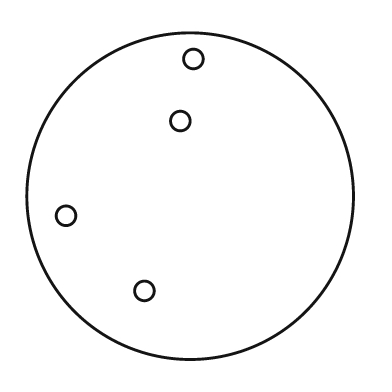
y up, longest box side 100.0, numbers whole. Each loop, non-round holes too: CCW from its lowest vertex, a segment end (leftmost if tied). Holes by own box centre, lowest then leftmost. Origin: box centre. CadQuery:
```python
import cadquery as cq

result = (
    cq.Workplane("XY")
    .moveTo(0.0, 0.0)
    .circle(50.0)
    .moveTo(-14.0, -29.0)
    .circle(3.0)
    .moveTo(-38.0, -6.0)
    .circle(3.0)
    .moveTo(-3.0, 23.0)
    .circle(3.0)
    .moveTo(1.0, 42.0)
    .circle(3.0)
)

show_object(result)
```